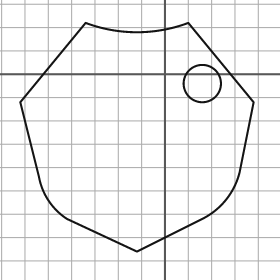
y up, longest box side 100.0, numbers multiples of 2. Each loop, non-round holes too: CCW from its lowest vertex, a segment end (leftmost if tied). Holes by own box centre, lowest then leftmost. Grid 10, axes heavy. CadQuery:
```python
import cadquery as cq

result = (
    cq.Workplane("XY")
    .moveTo(-12.0, -76.0)
    .lineTo(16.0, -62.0)
    .threePointArc((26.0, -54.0), (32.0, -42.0))
    .lineTo(38.0, -12.0)
    .lineTo(10.0, 22.0)
    .threePointArc((-12.0, 18.0), (-34.0, 22.0))
    .lineTo(-62.0, -12.0)
    .lineTo(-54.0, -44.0)
    .threePointArc((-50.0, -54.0), (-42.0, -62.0))
    .close()
    .moveTo(16.0, -4.0)
    .circle(8.0)
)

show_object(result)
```